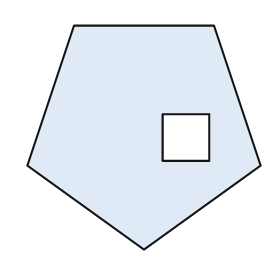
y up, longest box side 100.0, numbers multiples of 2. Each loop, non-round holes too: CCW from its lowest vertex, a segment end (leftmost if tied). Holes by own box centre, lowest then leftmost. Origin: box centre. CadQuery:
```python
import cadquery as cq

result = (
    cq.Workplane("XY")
    .moveTo(0.0, -48.0)
    .lineTo(50.0, -12.0)
    .lineTo(30.0, 48.0)
    .lineTo(-30.0, 48.0)
    .lineTo(-50.0, -12.0)
    .close()
    .moveTo(8.0, -10.0)
    .lineTo(28.0, -10.0)
    .lineTo(28.0, 10.0)
    .lineTo(8.0, 10.0)
    .close()
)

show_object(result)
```